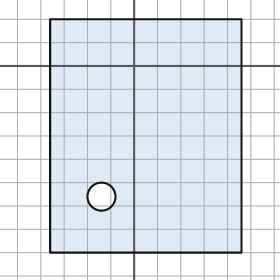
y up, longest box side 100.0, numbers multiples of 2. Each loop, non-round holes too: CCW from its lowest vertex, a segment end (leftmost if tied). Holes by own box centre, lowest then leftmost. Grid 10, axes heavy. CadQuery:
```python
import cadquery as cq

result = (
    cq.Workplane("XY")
    .moveTo(-36.0, -80.0)
    .lineTo(46.0, -80.0)
    .lineTo(46.0, 20.0)
    .lineTo(-36.0, 20.0)
    .close()
    .moveTo(-14.0, -56.0)
    .circle(6.0)
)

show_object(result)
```